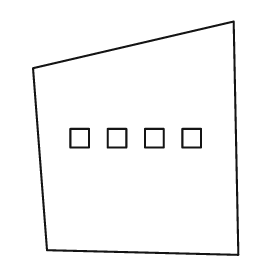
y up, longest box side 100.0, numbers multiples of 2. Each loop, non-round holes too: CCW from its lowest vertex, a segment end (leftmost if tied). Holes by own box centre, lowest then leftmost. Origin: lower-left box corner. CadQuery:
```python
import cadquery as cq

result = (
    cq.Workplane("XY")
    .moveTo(88.0, 0.0)
    .lineTo(86.0, 100.0)
    .lineTo(0.0, 80.0)
    .lineTo(6.0, 2.0)
    .close()
    .moveTo(16.0, 46.0)
    .lineTo(24.0, 46.0)
    .lineTo(24.0, 54.0)
    .lineTo(16.0, 54.0)
    .close()
    .moveTo(32.0, 46.0)
    .lineTo(40.0, 46.0)
    .lineTo(40.0, 54.0)
    .lineTo(32.0, 54.0)
    .close()
    .moveTo(48.0, 46.0)
    .lineTo(56.0, 46.0)
    .lineTo(56.0, 54.0)
    .lineTo(48.0, 54.0)
    .close()
    .moveTo(64.0, 46.0)
    .lineTo(72.0, 46.0)
    .lineTo(72.0, 54.0)
    .lineTo(64.0, 54.0)
    .close()
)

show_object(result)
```